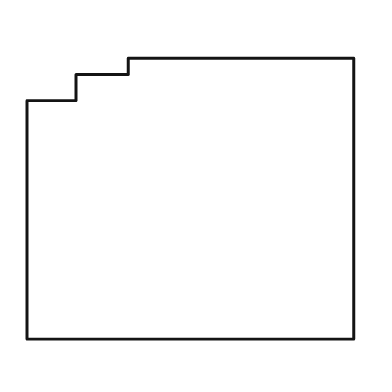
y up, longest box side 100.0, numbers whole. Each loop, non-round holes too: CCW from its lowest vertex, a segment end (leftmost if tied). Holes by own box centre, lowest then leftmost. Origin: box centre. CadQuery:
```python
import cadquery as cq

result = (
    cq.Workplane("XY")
    .moveTo(-50.0, -43.0)
    .lineTo(50.0, -43.0)
    .lineTo(50.0, 43.0)
    .lineTo(-19.0, 43.0)
    .lineTo(-19.0, 38.0)
    .lineTo(-35.0, 38.0)
    .lineTo(-35.0, 30.0)
    .lineTo(-50.0, 30.0)
    .close()
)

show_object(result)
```